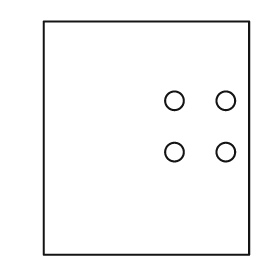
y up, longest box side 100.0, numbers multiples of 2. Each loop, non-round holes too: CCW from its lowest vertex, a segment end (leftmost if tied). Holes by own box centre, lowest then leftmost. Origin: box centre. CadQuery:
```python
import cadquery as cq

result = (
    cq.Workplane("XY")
    .moveTo(-44.0, -50.0)
    .lineTo(44.0, -50.0)
    .lineTo(44.0, 50.0)
    .lineTo(-44.0, 50.0)
    .close()
    .moveTo(12.0, -6.0)
    .circle(4.0)
    .moveTo(34.0, -6.0)
    .circle(4.0)
    .moveTo(12.0, 16.0)
    .circle(4.0)
    .moveTo(34.0, 16.0)
    .circle(4.0)
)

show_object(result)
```